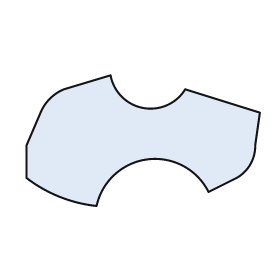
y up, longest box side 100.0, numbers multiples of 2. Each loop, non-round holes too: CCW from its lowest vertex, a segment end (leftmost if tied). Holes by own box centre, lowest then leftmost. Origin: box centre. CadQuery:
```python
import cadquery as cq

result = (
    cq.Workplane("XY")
    .moveTo(-20.0, -28.0)
    .threePointArc((2.0, -8.0), (28.0, -22.0))
    .lineTo(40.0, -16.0)
    .threePointArc((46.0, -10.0), (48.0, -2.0))
    .lineTo(50.0, 12.0)
    .lineTo(18.0, 22.0)
    .threePointArc((0.0, 14.0), (-14.0, 28.0))
    .lineTo(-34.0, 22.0)
    .threePointArc((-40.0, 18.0), (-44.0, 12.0))
    .lineTo(-50.0, -2.0)
    .lineTo(-50.0, -16.0)
    .threePointArc((-36.0, -24.0), (-20.0, -28.0))
    .close()
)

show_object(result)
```